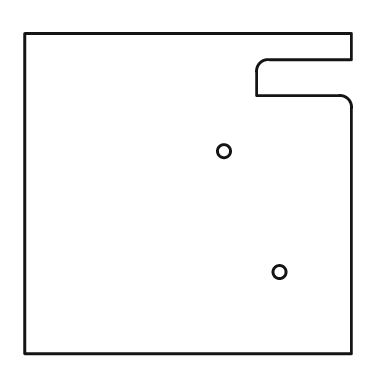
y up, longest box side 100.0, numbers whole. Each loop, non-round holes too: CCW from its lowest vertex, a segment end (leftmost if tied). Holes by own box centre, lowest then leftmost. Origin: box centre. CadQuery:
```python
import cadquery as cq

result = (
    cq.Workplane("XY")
    .moveTo(-50.0, -49.0)
    .lineTo(50.0, -49.0)
    .lineTo(50.0, 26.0)
    .threePointArc((49.0, 29.0), (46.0, 30.0))
    .lineTo(21.0, 30.0)
    .lineTo(21.0, 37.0)
    .threePointArc((22.0, 40.0), (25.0, 41.0))
    .lineTo(50.0, 41.0)
    .lineTo(50.0, 49.0)
    .lineTo(-50.0, 49.0)
    .close()
    .moveTo(28.0, -24.0)
    .circle(2.0)
    .moveTo(11.0, 13.0)
    .circle(2.0)
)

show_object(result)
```